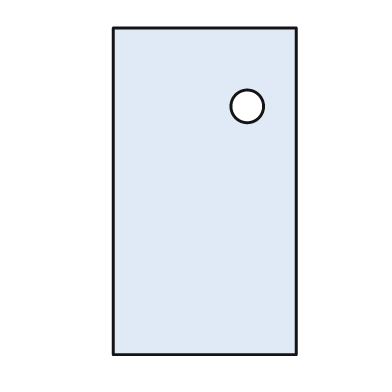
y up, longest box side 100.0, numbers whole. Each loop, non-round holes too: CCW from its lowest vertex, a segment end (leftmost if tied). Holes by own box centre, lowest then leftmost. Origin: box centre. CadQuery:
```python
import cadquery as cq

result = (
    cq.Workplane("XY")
    .moveTo(-28.0, -50.0)
    .lineTo(28.0, -50.0)
    .lineTo(28.0, 50.0)
    .lineTo(-28.0, 50.0)
    .close()
    .moveTo(13.0, 26.0)
    .circle(5.0)
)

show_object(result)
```